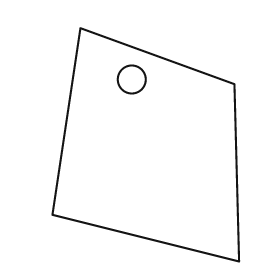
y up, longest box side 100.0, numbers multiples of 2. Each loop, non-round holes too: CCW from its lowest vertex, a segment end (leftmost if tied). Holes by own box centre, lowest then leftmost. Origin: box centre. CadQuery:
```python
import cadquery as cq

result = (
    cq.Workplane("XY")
    .moveTo(40.0, -50.0)
    .lineTo(38.0, 26.0)
    .lineTo(-28.0, 50.0)
    .lineTo(-40.0, -30.0)
    .close()
    .moveTo(-6.0, 28.0)
    .circle(6.0)
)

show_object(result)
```